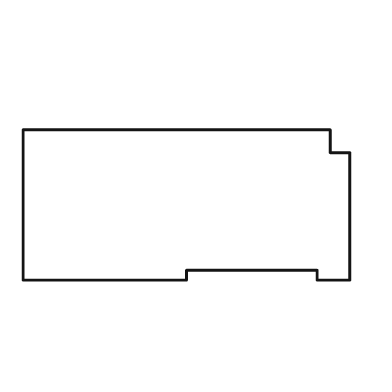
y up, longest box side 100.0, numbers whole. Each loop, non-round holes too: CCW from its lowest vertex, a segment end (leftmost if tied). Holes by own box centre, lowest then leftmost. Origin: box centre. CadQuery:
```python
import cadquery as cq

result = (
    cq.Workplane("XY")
    .moveTo(-50.0, -23.0)
    .lineTo(0.0, -23.0)
    .lineTo(0.0, -20.0)
    .lineTo(40.0, -20.0)
    .lineTo(40.0, -23.0)
    .lineTo(50.0, -23.0)
    .lineTo(50.0, 16.0)
    .lineTo(44.0, 16.0)
    .lineTo(44.0, 23.0)
    .lineTo(-50.0, 23.0)
    .close()
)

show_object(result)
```